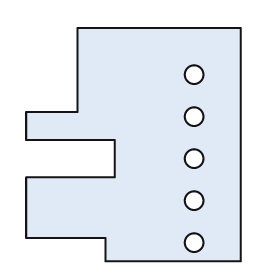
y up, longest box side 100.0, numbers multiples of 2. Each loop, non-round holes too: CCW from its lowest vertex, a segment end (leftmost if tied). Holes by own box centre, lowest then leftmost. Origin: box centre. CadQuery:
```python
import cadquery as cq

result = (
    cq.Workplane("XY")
    .moveTo(-12.0, -50.0)
    .lineTo(46.0, -50.0)
    .lineTo(46.0, 50.0)
    .lineTo(-24.0, 50.0)
    .lineTo(-24.0, 14.0)
    .lineTo(-46.0, 14.0)
    .lineTo(-46.0, 2.0)
    .lineTo(-8.0, 2.0)
    .lineTo(-8.0, -14.0)
    .lineTo(-46.0, -14.0)
    .lineTo(-46.0, -40.0)
    .lineTo(-12.0, -40.0)
    .close()
    .moveTo(26.0, -42.0)
    .circle(4.0)
    .moveTo(26.0, -24.0)
    .circle(4.0)
    .moveTo(26.0, -6.0)
    .circle(4.0)
    .moveTo(26.0, 12.0)
    .circle(4.0)
    .moveTo(26.0, 30.0)
    .circle(4.0)
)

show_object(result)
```